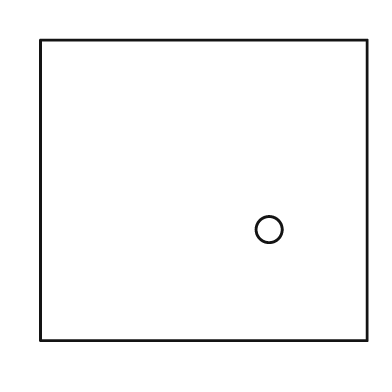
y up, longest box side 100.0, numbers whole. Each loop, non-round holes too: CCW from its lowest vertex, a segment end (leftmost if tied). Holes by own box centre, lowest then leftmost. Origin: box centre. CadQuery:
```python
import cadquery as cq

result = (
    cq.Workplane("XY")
    .moveTo(-50.0, -46.0)
    .lineTo(50.0, -46.0)
    .lineTo(50.0, 46.0)
    .lineTo(-50.0, 46.0)
    .close()
    .moveTo(20.0, -12.0)
    .circle(4.0)
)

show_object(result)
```